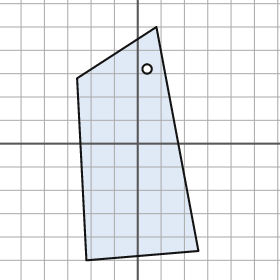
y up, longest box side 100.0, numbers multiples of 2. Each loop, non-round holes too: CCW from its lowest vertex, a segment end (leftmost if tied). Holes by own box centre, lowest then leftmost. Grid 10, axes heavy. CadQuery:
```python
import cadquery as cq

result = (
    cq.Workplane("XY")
    .moveTo(-22.0, -50.0)
    .lineTo(26.0, -46.0)
    .lineTo(8.0, 50.0)
    .lineTo(-26.0, 28.0)
    .close()
    .moveTo(4.0, 32.0)
    .circle(2.0)
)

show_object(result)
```